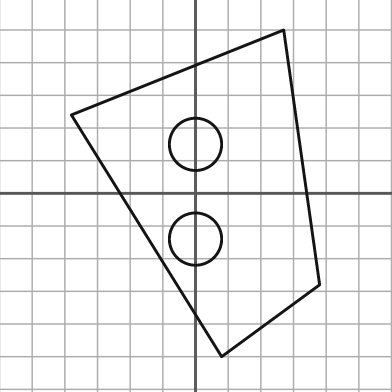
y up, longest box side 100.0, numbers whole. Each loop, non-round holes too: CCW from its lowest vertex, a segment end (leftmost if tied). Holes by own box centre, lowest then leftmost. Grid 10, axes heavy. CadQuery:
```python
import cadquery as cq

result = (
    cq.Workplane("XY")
    .moveTo(8.0, -50.0)
    .lineTo(38.0, -28.0)
    .lineTo(27.0, 50.0)
    .lineTo(-38.0, 24.0)
    .close()
    .moveTo(0.0, -14.0)
    .circle(8.0)
    .moveTo(0.0, 15.0)
    .circle(8.0)
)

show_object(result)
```